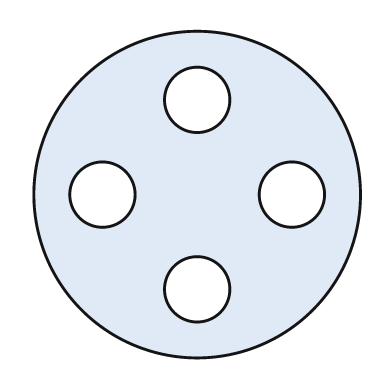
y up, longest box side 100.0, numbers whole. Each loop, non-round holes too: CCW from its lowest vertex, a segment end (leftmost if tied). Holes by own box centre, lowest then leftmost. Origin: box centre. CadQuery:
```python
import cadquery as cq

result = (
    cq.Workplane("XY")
    .moveTo(0.0, 0.0)
    .circle(50.0)
    .moveTo(0.0, -29.0)
    .circle(10.0)
    .moveTo(-29.0, 0.0)
    .circle(10.0)
    .moveTo(29.0, 0.0)
    .circle(10.0)
    .moveTo(0.0, 29.0)
    .circle(10.0)
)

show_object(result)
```